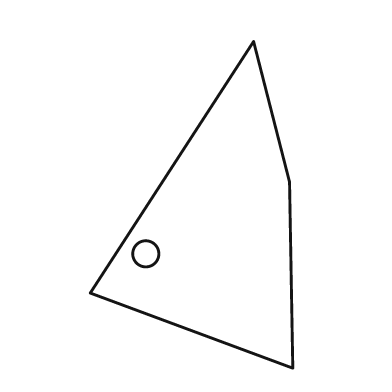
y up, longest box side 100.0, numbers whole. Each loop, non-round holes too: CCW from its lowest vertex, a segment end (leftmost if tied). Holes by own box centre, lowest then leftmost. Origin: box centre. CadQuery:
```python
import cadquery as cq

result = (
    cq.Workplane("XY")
    .moveTo(31.0, -50.0)
    .lineTo(30.0, 7.0)
    .lineTo(19.0, 50.0)
    .lineTo(-31.0, -27.0)
    .close()
    .moveTo(-14.0, -15.0)
    .circle(4.0)
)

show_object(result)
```